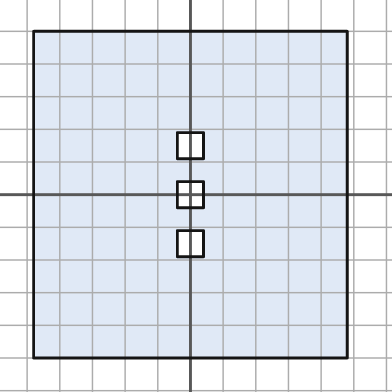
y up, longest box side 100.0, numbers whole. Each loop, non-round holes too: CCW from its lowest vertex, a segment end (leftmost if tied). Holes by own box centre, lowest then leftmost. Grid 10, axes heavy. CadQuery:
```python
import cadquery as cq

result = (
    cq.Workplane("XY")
    .moveTo(-48.0, -50.0)
    .lineTo(48.0, -50.0)
    .lineTo(48.0, 50.0)
    .lineTo(-48.0, 50.0)
    .close()
    .moveTo(-4.0, -19.0)
    .lineTo(4.0, -19.0)
    .lineTo(4.0, -11.0)
    .lineTo(-4.0, -11.0)
    .close()
    .moveTo(-4.0, -4.0)
    .lineTo(4.0, -4.0)
    .lineTo(4.0, 4.0)
    .lineTo(-4.0, 4.0)
    .close()
    .moveTo(-4.0, 11.0)
    .lineTo(4.0, 11.0)
    .lineTo(4.0, 19.0)
    .lineTo(-4.0, 19.0)
    .close()
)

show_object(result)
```